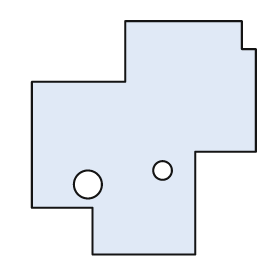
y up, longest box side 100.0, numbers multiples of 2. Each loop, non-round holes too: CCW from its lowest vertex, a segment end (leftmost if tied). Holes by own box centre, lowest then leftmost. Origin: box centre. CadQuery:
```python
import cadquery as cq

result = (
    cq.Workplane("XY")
    .moveTo(-22.0, -50.0)
    .lineTo(22.0, -50.0)
    .lineTo(22.0, -6.0)
    .lineTo(48.0, -6.0)
    .lineTo(48.0, 38.0)
    .lineTo(42.0, 38.0)
    .lineTo(42.0, 50.0)
    .lineTo(-8.0, 50.0)
    .lineTo(-8.0, 24.0)
    .lineTo(-48.0, 24.0)
    .lineTo(-48.0, -30.0)
    .lineTo(-22.0, -30.0)
    .close()
    .moveTo(-24.0, -20.0)
    .circle(6.0)
    .moveTo(8.0, -14.0)
    .circle(4.0)
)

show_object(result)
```